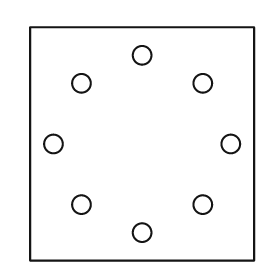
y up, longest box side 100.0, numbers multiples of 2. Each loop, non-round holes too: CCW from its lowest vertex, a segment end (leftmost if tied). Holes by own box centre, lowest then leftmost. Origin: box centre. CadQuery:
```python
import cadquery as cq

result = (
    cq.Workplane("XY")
    .moveTo(-48.0, -50.0)
    .lineTo(48.0, -50.0)
    .lineTo(48.0, 50.0)
    .lineTo(-48.0, 50.0)
    .close()
    .moveTo(0.0, -38.0)
    .circle(4.0)
    .moveTo(-26.0, -26.0)
    .circle(4.0)
    .moveTo(26.0, -26.0)
    .circle(4.0)
    .moveTo(-38.0, 0.0)
    .circle(4.0)
    .moveTo(38.0, 0.0)
    .circle(4.0)
    .moveTo(-26.0, 26.0)
    .circle(4.0)
    .moveTo(26.0, 26.0)
    .circle(4.0)
    .moveTo(0.0, 38.0)
    .circle(4.0)
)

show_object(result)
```